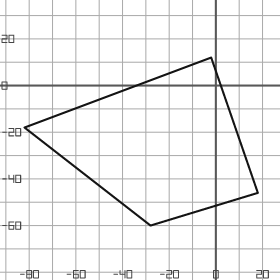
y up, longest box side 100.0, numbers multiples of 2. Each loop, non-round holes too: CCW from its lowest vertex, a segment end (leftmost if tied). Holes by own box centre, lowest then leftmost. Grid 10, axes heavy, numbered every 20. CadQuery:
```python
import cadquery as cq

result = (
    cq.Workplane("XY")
    .moveTo(-28.0, -60.0)
    .lineTo(18.0, -46.0)
    .lineTo(-2.0, 12.0)
    .lineTo(-82.0, -18.0)
    .close()
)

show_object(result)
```